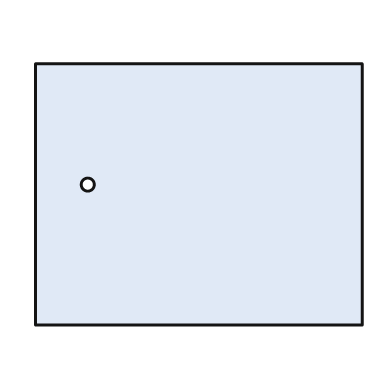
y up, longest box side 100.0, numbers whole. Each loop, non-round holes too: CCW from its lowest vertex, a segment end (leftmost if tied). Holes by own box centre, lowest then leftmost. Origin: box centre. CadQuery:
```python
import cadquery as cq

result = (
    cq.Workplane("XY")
    .moveTo(-50.0, -40.0)
    .lineTo(50.0, -40.0)
    .lineTo(50.0, 40.0)
    .lineTo(-50.0, 40.0)
    .close()
    .moveTo(-34.0, 3.0)
    .circle(2.0)
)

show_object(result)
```